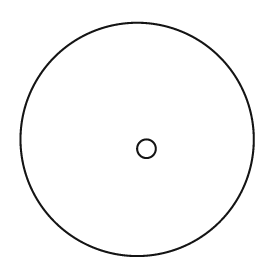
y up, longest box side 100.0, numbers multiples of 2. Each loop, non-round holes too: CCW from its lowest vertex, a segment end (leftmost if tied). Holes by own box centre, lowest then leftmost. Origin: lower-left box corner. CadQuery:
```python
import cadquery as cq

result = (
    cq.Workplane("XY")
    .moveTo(50.0, 50.0)
    .circle(50.0)
    .moveTo(54.0, 46.0)
    .circle(4.0)
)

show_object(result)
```